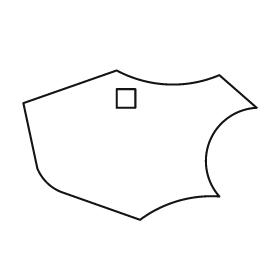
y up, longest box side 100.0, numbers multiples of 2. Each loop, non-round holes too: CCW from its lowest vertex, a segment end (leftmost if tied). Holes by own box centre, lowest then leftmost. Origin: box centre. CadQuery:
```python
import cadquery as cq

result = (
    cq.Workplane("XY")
    .moveTo(0.0, -32.0)
    .threePointArc((16.0, -24.0), (34.0, -22.0))
    .threePointArc((30.0, 2.0), (50.0, 16.0))
    .lineTo(34.0, 30.0)
    .threePointArc((12.0, 26.0), (-10.0, 32.0))
    .lineTo(-50.0, 18.0)
    .lineTo(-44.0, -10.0)
    .threePointArc((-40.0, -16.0), (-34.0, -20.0))
    .close()
    .moveTo(-10.0, 16.0)
    .lineTo(-2.0, 16.0)
    .lineTo(-2.0, 24.0)
    .lineTo(-10.0, 24.0)
    .close()
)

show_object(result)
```